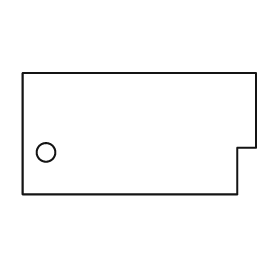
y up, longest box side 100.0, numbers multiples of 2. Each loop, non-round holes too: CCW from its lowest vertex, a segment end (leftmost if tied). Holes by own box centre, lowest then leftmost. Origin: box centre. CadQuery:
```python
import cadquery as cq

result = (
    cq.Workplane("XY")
    .moveTo(-50.0, -26.0)
    .lineTo(42.0, -26.0)
    .lineTo(42.0, -6.0)
    .lineTo(50.0, -6.0)
    .lineTo(50.0, 26.0)
    .lineTo(-50.0, 26.0)
    .close()
    .moveTo(-40.0, -8.0)
    .circle(4.0)
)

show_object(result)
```